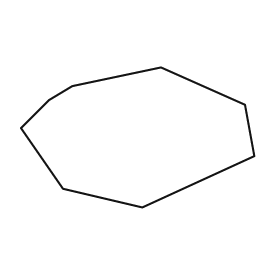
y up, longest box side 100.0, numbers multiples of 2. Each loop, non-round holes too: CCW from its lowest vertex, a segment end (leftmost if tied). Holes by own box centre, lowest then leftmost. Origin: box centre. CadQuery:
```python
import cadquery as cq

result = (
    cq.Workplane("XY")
    .moveTo(2.0, -30.0)
    .lineTo(50.0, -8.0)
    .lineTo(46.0, 14.0)
    .lineTo(10.0, 30.0)
    .lineTo(-28.0, 22.0)
    .lineTo(-38.0, 16.0)
    .lineTo(-50.0, 4.0)
    .lineTo(-32.0, -22.0)
    .close()
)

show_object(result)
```